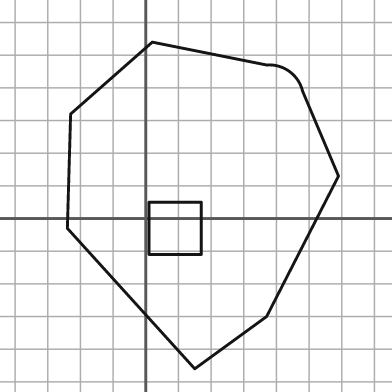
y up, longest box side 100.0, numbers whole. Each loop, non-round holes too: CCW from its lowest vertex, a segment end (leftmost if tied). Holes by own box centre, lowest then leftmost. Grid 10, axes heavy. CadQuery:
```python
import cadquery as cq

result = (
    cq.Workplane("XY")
    .moveTo(15.0, -46.0)
    .lineTo(37.0, -30.0)
    .lineTo(59.0, 13.0)
    .lineTo(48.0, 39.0)
    .threePointArc((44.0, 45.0), (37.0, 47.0))
    .lineTo(2.0, 54.0)
    .lineTo(-23.0, 32.0)
    .lineTo(-24.0, -3.0)
    .close()
    .moveTo(1.0, -11.0)
    .lineTo(17.0, -11.0)
    .lineTo(17.0, 5.0)
    .lineTo(1.0, 5.0)
    .close()
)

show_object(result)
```